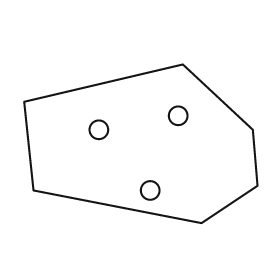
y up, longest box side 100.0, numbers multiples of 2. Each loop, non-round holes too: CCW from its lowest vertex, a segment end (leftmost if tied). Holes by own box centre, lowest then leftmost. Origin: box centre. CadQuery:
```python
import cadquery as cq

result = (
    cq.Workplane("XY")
    .moveTo(26.0, -34.0)
    .lineTo(50.0, -18.0)
    .lineTo(48.0, 6.0)
    .lineTo(18.0, 34.0)
    .lineTo(-50.0, 18.0)
    .lineTo(-46.0, -20.0)
    .close()
    .moveTo(4.0, -20.0)
    .circle(4.0)
    .moveTo(-18.0, 6.0)
    .circle(4.0)
    .moveTo(16.0, 12.0)
    .circle(4.0)
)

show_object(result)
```